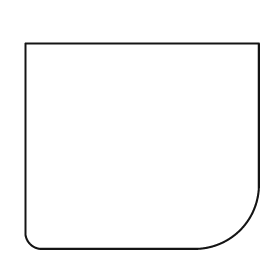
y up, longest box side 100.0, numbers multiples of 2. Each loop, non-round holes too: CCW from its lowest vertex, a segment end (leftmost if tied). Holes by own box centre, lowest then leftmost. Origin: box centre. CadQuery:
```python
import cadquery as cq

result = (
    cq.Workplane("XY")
    .moveTo(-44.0, -44.0)
    .lineTo(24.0, -44.0)
    .threePointArc((42.0, -36.0), (50.0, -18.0))
    .lineTo(50.0, 44.0)
    .lineTo(-50.0, 44.0)
    .lineTo(-50.0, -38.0)
    .threePointArc((-48.0, -42.0), (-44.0, -44.0))
    .close()
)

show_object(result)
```